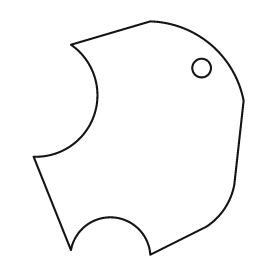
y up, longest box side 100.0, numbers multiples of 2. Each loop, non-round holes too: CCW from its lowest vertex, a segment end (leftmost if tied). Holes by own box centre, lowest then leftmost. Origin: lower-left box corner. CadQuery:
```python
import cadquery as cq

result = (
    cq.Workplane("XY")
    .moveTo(50.0, 0.0)
    .lineTo(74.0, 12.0)
    .threePointArc((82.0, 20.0), (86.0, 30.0))
    .lineTo(90.0, 66.0)
    .threePointArc((76.0, 90.0), (50.0, 100.0))
    .lineTo(16.0, 90.0)
    .threePointArc((26.0, 60.0), (0.0, 42.0))
    .lineTo(16.0, 2.0)
    .threePointArc((34.0, 16.0), (50.0, 0.0))
    .close()
    .moveTo(72.0, 80.0)
    .circle(4.0)
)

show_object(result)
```